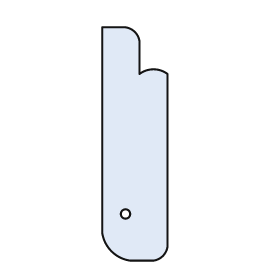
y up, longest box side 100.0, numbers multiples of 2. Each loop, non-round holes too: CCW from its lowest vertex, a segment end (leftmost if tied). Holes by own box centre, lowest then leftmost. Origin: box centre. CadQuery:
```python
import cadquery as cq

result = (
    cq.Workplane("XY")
    .moveTo(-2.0, -50.0)
    .lineTo(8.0, -50.0)
    .threePointArc((12.0, -48.0), (14.0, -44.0))
    .lineTo(14.0, 30.0)
    .threePointArc((8.0, 32.0), (2.0, 30.0))
    .lineTo(2.0, 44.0)
    .threePointArc((0.0, 48.0), (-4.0, 50.0))
    .lineTo(-14.0, 50.0)
    .lineTo(-14.0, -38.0)
    .threePointArc((-10.0, -46.0), (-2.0, -50.0))
    .close()
    .moveTo(-4.0, -30.0)
    .circle(2.0)
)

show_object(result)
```